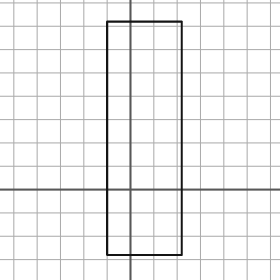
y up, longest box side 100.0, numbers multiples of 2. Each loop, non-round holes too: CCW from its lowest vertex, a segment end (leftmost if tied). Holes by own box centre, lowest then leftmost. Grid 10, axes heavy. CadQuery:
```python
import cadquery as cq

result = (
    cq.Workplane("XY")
    .moveTo(-10.0, -28.0)
    .lineTo(22.0, -28.0)
    .lineTo(22.0, 72.0)
    .lineTo(-10.0, 72.0)
    .close()
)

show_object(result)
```